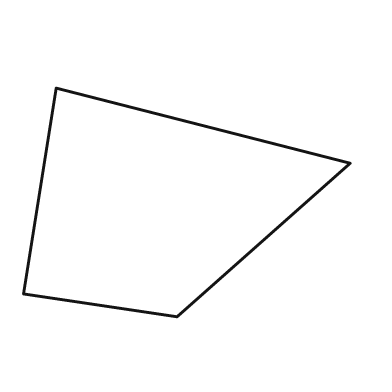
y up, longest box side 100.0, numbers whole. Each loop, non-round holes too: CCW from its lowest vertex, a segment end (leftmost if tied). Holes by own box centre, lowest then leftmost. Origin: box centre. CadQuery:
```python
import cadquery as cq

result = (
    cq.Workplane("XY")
    .moveTo(-3.0, -35.0)
    .lineTo(50.0, 12.0)
    .lineTo(-40.0, 35.0)
    .lineTo(-50.0, -28.0)
    .close()
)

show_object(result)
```